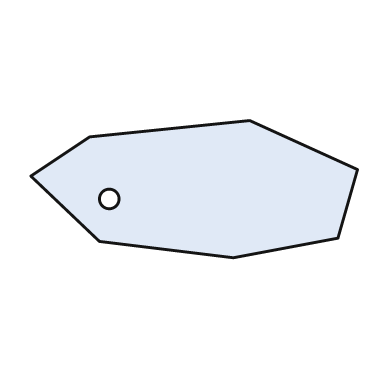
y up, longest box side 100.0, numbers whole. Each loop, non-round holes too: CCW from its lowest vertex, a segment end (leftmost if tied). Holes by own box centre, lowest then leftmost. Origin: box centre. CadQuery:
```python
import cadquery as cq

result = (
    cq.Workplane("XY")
    .moveTo(12.0, -21.0)
    .lineTo(44.0, -15.0)
    .lineTo(50.0, 6.0)
    .lineTo(17.0, 21.0)
    .lineTo(-32.0, 16.0)
    .lineTo(-50.0, 4.0)
    .lineTo(-29.0, -16.0)
    .close()
    .moveTo(-26.0, -3.0)
    .circle(3.0)
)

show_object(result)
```